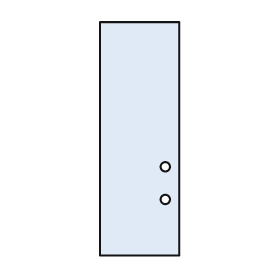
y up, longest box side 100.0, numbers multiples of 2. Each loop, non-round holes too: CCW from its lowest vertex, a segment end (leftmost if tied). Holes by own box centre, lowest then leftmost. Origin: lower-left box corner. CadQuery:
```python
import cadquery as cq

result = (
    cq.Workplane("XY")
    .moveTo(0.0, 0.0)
    .lineTo(34.0, 0.0)
    .lineTo(34.0, 100.0)
    .lineTo(0.0, 100.0)
    .close()
    .moveTo(28.0, 24.0)
    .circle(2.0)
    .moveTo(28.0, 38.0)
    .circle(2.0)
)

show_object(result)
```